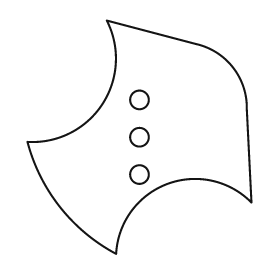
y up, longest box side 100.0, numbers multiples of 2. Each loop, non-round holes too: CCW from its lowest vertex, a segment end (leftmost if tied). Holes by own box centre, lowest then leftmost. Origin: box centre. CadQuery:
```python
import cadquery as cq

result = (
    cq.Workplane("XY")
    .moveTo(-10.0, -50.0)
    .threePointArc((12.0, -20.0), (48.0, -28.0))
    .lineTo(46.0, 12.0)
    .threePointArc((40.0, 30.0), (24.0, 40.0))
    .lineTo(-14.0, 50.0)
    .threePointArc((-16.0, 14.0), (-48.0, -2.0))
    .threePointArc((-34.0, -30.0), (-10.0, -50.0))
    .close()
    .moveTo(0.0, -16.0)
    .circle(4.0)
    .moveTo(0.0, 0.0)
    .circle(4.0)
    .moveTo(0.0, 16.0)
    .circle(4.0)
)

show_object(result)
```